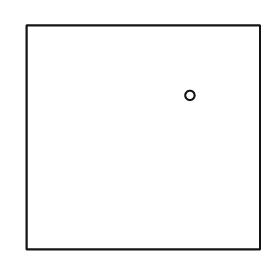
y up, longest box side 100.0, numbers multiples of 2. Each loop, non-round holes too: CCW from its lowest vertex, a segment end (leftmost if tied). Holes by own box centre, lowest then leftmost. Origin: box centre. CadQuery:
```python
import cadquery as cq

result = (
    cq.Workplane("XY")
    .moveTo(-50.0, -48.0)
    .lineTo(50.0, -48.0)
    .lineTo(50.0, 48.0)
    .lineTo(-50.0, 48.0)
    .close()
    .moveTo(20.0, 18.0)
    .circle(2.0)
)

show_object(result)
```